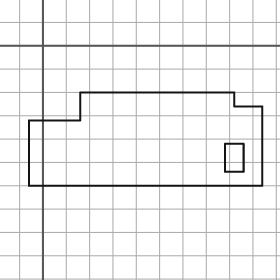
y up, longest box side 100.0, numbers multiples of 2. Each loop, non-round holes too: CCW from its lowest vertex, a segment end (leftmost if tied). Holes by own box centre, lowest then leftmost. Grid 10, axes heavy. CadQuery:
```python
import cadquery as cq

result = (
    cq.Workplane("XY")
    .moveTo(-6.0, -60.0)
    .lineTo(94.0, -60.0)
    .lineTo(94.0, -26.0)
    .lineTo(82.0, -26.0)
    .lineTo(82.0, -20.0)
    .lineTo(16.0, -20.0)
    .lineTo(16.0, -32.0)
    .lineTo(-6.0, -32.0)
    .close()
    .moveTo(78.0, -54.0)
    .lineTo(86.0, -54.0)
    .lineTo(86.0, -42.0)
    .lineTo(78.0, -42.0)
    .close()
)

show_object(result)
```